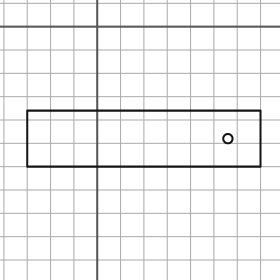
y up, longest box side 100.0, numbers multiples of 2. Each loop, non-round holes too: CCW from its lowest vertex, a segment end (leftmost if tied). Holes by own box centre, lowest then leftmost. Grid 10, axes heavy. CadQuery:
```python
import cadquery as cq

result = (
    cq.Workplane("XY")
    .moveTo(-30.0, -60.0)
    .lineTo(70.0, -60.0)
    .lineTo(70.0, -36.0)
    .lineTo(-30.0, -36.0)
    .close()
    .moveTo(56.0, -48.0)
    .circle(2.0)
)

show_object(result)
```